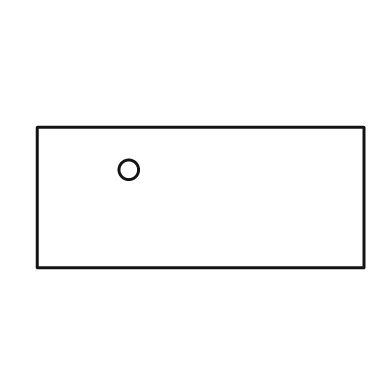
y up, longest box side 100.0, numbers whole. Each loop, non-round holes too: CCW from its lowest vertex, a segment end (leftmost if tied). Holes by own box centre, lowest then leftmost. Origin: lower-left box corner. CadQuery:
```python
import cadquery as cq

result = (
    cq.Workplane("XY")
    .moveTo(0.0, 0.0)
    .lineTo(100.0, 0.0)
    .lineTo(100.0, 43.0)
    .lineTo(0.0, 43.0)
    .close()
    .moveTo(28.0, 30.0)
    .circle(3.0)
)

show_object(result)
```